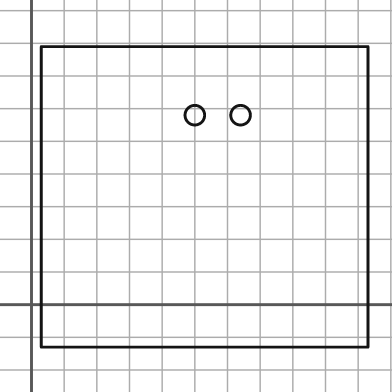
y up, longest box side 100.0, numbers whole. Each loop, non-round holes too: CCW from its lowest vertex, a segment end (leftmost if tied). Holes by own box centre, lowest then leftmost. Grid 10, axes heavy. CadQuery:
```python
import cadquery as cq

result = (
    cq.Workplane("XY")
    .moveTo(3.0, -13.0)
    .lineTo(103.0, -13.0)
    .lineTo(103.0, 79.0)
    .lineTo(3.0, 79.0)
    .close()
    .moveTo(50.0, 58.0)
    .circle(3.0)
    .moveTo(64.0, 58.0)
    .circle(3.0)
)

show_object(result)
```